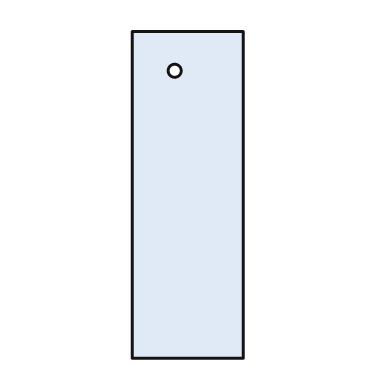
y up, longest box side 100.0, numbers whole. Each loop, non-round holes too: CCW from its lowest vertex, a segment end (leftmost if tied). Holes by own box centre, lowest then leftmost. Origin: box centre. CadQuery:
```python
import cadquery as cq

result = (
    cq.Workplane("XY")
    .moveTo(-17.0, -50.0)
    .lineTo(17.0, -50.0)
    .lineTo(17.0, 50.0)
    .lineTo(-17.0, 50.0)
    .close()
    .moveTo(-4.0, 38.0)
    .circle(2.0)
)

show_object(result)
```